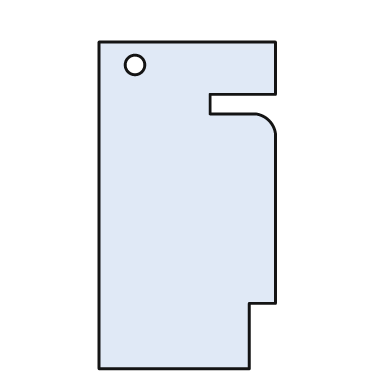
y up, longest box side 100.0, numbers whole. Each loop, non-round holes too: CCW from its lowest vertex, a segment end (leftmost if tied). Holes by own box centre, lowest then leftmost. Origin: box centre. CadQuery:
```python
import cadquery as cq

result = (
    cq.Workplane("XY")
    .moveTo(-27.0, -50.0)
    .lineTo(19.0, -50.0)
    .lineTo(19.0, -30.0)
    .lineTo(27.0, -30.0)
    .lineTo(27.0, 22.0)
    .threePointArc((25.0, 26.0), (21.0, 28.0))
    .lineTo(7.0, 28.0)
    .lineTo(7.0, 34.0)
    .lineTo(27.0, 34.0)
    .lineTo(27.0, 50.0)
    .lineTo(-27.0, 50.0)
    .close()
    .moveTo(-16.0, 43.0)
    .circle(3.0)
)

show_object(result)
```